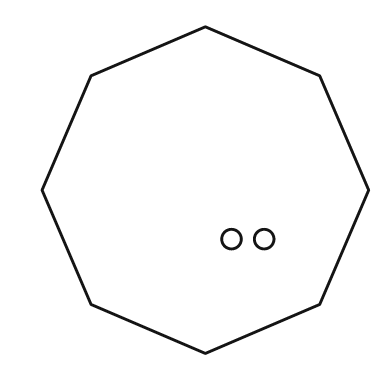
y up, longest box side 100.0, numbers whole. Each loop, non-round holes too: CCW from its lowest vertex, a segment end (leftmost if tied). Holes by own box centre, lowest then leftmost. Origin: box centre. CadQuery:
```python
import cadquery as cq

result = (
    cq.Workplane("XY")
    .moveTo(0.0, -50.0)
    .lineTo(35.0, -35.0)
    .lineTo(50.0, 0.0)
    .lineTo(35.0, 35.0)
    .lineTo(0.0, 50.0)
    .lineTo(-35.0, 35.0)
    .lineTo(-50.0, 0.0)
    .lineTo(-35.0, -35.0)
    .close()
    .moveTo(8.0, -15.0)
    .circle(3.0)
    .moveTo(18.0, -15.0)
    .circle(3.0)
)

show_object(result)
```